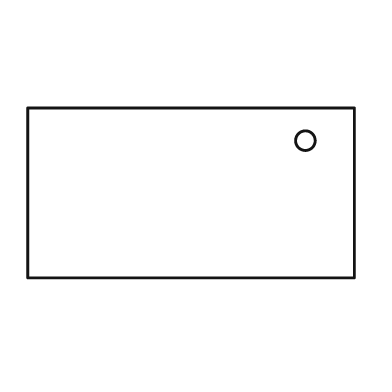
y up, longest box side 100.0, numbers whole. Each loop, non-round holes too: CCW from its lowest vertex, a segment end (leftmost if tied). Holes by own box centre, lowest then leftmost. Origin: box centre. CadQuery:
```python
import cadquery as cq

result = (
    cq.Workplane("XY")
    .moveTo(-50.0, -26.0)
    .lineTo(50.0, -26.0)
    .lineTo(50.0, 26.0)
    .lineTo(-50.0, 26.0)
    .close()
    .moveTo(35.0, 16.0)
    .circle(3.0)
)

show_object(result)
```